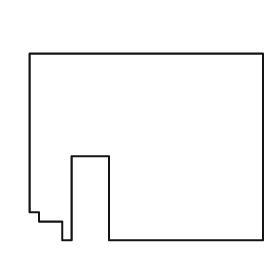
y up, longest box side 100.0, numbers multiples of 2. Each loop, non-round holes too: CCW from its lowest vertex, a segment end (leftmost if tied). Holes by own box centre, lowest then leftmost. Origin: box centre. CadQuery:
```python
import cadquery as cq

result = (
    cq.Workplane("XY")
    .moveTo(-36.0, -40.0)
    .lineTo(-32.0, -40.0)
    .lineTo(-32.0, -4.0)
    .lineTo(-16.0, -4.0)
    .lineTo(-16.0, -40.0)
    .lineTo(50.0, -40.0)
    .lineTo(50.0, 40.0)
    .lineTo(-50.0, 40.0)
    .lineTo(-50.0, -28.0)
    .lineTo(-46.0, -28.0)
    .lineTo(-46.0, -32.0)
    .lineTo(-36.0, -32.0)
    .close()
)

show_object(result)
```